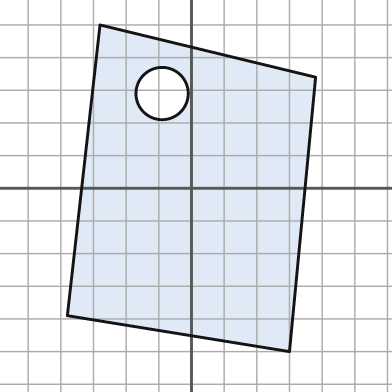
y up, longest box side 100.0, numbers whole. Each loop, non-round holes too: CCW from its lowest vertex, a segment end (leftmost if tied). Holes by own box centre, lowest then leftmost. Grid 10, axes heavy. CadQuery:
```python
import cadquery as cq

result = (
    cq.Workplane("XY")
    .moveTo(30.0, -50.0)
    .lineTo(38.0, 34.0)
    .lineTo(-28.0, 50.0)
    .lineTo(-38.0, -39.0)
    .close()
    .moveTo(-9.0, 29.0)
    .circle(8.0)
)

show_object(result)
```